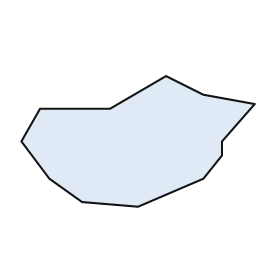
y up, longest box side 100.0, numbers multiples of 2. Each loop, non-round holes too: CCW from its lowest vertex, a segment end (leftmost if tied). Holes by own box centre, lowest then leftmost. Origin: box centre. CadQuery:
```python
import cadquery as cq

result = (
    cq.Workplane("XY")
    .moveTo(0.0, -28.0)
    .lineTo(28.0, -16.0)
    .lineTo(36.0, -6.0)
    .lineTo(36.0, 0.0)
    .lineTo(50.0, 16.0)
    .lineTo(28.0, 20.0)
    .lineTo(12.0, 28.0)
    .lineTo(-12.0, 14.0)
    .lineTo(-42.0, 14.0)
    .lineTo(-50.0, 0.0)
    .lineTo(-38.0, -16.0)
    .lineTo(-24.0, -26.0)
    .close()
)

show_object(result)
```